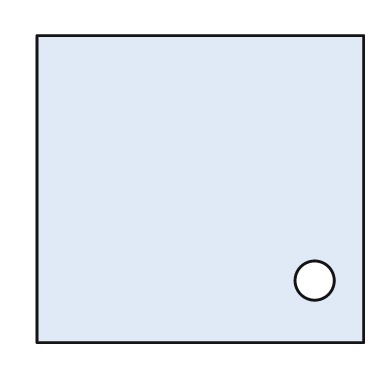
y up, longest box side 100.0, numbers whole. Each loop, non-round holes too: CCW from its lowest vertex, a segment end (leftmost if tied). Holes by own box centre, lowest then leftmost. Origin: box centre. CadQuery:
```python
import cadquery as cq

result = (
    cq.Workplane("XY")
    .moveTo(-50.0, -47.0)
    .lineTo(50.0, -47.0)
    .lineTo(50.0, 47.0)
    .lineTo(-50.0, 47.0)
    .close()
    .moveTo(35.0, -28.0)
    .circle(6.0)
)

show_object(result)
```